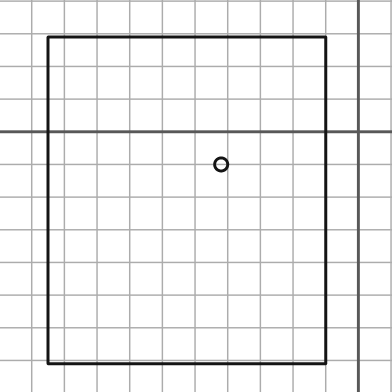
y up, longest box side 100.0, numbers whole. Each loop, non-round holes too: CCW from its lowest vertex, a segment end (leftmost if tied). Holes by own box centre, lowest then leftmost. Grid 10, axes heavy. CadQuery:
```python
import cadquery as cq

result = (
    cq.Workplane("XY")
    .moveTo(-95.0, -71.0)
    .lineTo(-10.0, -71.0)
    .lineTo(-10.0, 29.0)
    .lineTo(-95.0, 29.0)
    .close()
    .moveTo(-42.0, -10.0)
    .circle(2.0)
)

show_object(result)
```